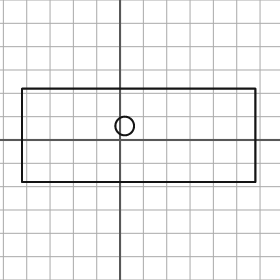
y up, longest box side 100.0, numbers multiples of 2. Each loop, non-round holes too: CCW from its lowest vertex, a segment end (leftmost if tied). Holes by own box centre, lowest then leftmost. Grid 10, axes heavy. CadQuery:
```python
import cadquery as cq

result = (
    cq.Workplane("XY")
    .moveTo(-42.0, -18.0)
    .lineTo(58.0, -18.0)
    .lineTo(58.0, 22.0)
    .lineTo(-42.0, 22.0)
    .close()
    .moveTo(2.0, 6.0)
    .circle(4.0)
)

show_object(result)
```